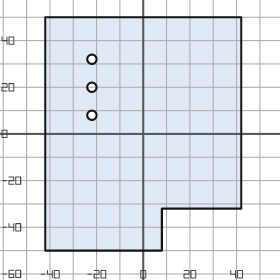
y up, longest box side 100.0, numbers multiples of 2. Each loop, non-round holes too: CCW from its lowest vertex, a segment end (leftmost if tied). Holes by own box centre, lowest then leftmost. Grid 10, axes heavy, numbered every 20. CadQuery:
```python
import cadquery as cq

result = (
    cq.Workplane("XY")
    .moveTo(-42.0, -50.0)
    .lineTo(8.0, -50.0)
    .lineTo(8.0, -32.0)
    .lineTo(42.0, -32.0)
    .lineTo(42.0, 50.0)
    .lineTo(-42.0, 50.0)
    .close()
    .moveTo(-22.0, 8.0)
    .circle(2.0)
    .moveTo(-22.0, 20.0)
    .circle(2.0)
    .moveTo(-22.0, 32.0)
    .circle(2.0)
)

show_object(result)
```